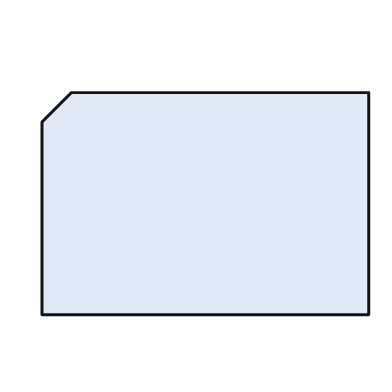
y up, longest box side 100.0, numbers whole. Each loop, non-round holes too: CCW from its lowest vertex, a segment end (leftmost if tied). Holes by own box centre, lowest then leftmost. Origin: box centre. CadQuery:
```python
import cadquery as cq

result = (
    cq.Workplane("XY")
    .moveTo(-50.0, -34.0)
    .lineTo(50.0, -34.0)
    .lineTo(50.0, 34.0)
    .lineTo(-41.0, 34.0)
    .lineTo(-50.0, 25.0)
    .close()
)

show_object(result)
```